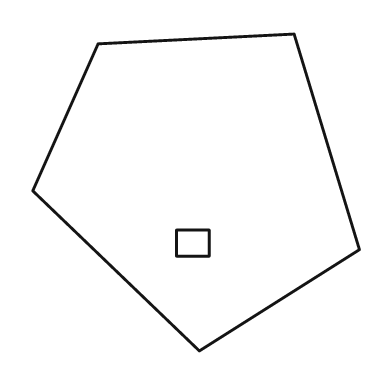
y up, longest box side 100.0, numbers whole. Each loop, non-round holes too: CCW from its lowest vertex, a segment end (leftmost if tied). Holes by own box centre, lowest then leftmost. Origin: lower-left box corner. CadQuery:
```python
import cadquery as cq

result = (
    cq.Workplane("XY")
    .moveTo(51.0, 0.0)
    .lineTo(100.0, 31.0)
    .lineTo(80.0, 97.0)
    .lineTo(20.0, 94.0)
    .lineTo(0.0, 49.0)
    .close()
    .moveTo(44.0, 29.0)
    .lineTo(54.0, 29.0)
    .lineTo(54.0, 37.0)
    .lineTo(44.0, 37.0)
    .close()
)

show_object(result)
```